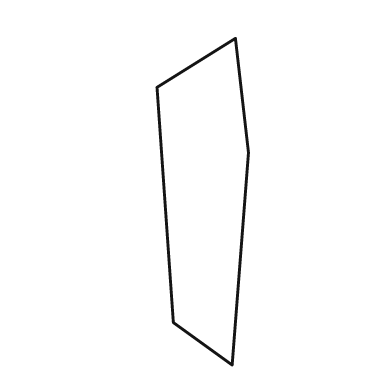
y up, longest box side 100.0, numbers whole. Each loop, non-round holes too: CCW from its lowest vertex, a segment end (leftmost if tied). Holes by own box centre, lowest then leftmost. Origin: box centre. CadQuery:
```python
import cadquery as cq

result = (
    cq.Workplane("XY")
    .moveTo(9.0, -50.0)
    .lineTo(14.0, 15.0)
    .lineTo(10.0, 50.0)
    .lineTo(-14.0, 35.0)
    .lineTo(-9.0, -37.0)
    .close()
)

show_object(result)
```